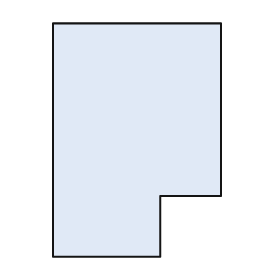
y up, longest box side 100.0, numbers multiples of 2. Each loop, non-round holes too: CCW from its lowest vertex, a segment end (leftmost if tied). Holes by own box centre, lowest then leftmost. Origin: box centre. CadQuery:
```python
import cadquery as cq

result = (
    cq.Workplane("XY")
    .moveTo(-36.0, -50.0)
    .lineTo(10.0, -50.0)
    .lineTo(10.0, -24.0)
    .lineTo(36.0, -24.0)
    .lineTo(36.0, 50.0)
    .lineTo(-36.0, 50.0)
    .close()
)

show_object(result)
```